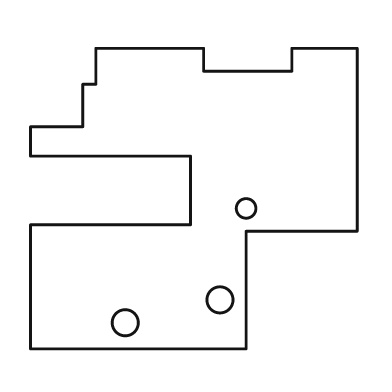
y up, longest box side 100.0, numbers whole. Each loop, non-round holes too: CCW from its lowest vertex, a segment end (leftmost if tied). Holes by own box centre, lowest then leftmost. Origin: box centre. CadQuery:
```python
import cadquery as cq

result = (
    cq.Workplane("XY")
    .moveTo(-50.0, -46.0)
    .lineTo(16.0, -46.0)
    .lineTo(16.0, -10.0)
    .lineTo(50.0, -10.0)
    .lineTo(50.0, 46.0)
    .lineTo(30.0, 46.0)
    .lineTo(30.0, 39.0)
    .lineTo(3.0, 39.0)
    .lineTo(3.0, 46.0)
    .lineTo(-30.0, 46.0)
    .lineTo(-30.0, 35.0)
    .lineTo(-34.0, 35.0)
    .lineTo(-34.0, 22.0)
    .lineTo(-50.0, 22.0)
    .lineTo(-50.0, 13.0)
    .lineTo(-1.0, 13.0)
    .lineTo(-1.0, -8.0)
    .lineTo(-50.0, -8.0)
    .close()
    .moveTo(-21.0, -38.0)
    .circle(4.0)
    .moveTo(8.0, -31.0)
    .circle(4.0)
    .moveTo(16.0, -3.0)
    .circle(3.0)
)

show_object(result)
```